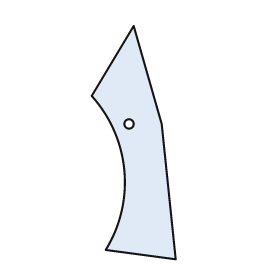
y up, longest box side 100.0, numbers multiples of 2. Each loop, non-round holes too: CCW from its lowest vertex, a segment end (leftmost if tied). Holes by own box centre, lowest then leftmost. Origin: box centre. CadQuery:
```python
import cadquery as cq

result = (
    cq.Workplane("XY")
    .moveTo(18.0, -50.0)
    .lineTo(12.0, 8.0)
    .lineTo(0.0, 50.0)
    .lineTo(-18.0, 20.0)
    .threePointArc((-4.0, -12.0), (-12.0, -46.0))
    .close()
    .moveTo(-2.0, 8.0)
    .circle(2.0)
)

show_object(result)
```